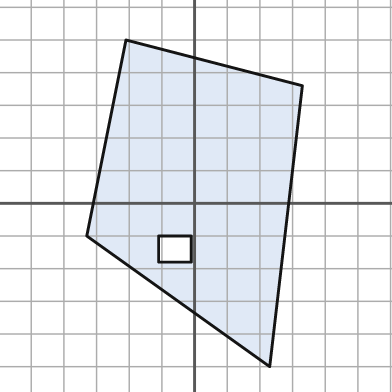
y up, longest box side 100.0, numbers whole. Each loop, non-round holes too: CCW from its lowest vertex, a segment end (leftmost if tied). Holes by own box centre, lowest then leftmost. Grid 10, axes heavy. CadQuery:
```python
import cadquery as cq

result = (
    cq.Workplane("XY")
    .moveTo(23.0, -50.0)
    .lineTo(33.0, 36.0)
    .lineTo(-21.0, 50.0)
    .lineTo(-33.0, -10.0)
    .close()
    .moveTo(-11.0, -18.0)
    .lineTo(-1.0, -18.0)
    .lineTo(-1.0, -10.0)
    .lineTo(-11.0, -10.0)
    .close()
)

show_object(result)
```